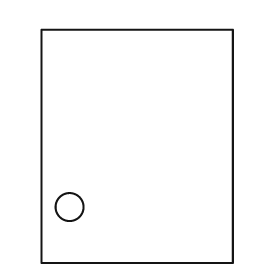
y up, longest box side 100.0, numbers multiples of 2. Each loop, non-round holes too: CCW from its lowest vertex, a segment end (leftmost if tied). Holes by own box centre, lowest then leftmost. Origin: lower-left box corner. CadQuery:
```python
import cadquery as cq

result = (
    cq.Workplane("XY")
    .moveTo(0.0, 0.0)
    .lineTo(82.0, 0.0)
    .lineTo(82.0, 100.0)
    .lineTo(0.0, 100.0)
    .close()
    .moveTo(12.0, 24.0)
    .circle(6.0)
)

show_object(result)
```